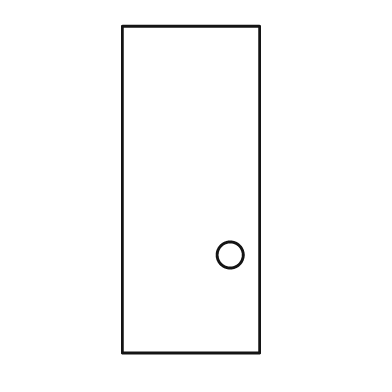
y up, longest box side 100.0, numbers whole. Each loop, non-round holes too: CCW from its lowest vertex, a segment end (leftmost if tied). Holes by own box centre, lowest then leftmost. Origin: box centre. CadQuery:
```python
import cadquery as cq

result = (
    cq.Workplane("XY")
    .moveTo(-21.0, -50.0)
    .lineTo(21.0, -50.0)
    .lineTo(21.0, 50.0)
    .lineTo(-21.0, 50.0)
    .close()
    .moveTo(12.0, -20.0)
    .circle(4.0)
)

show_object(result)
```